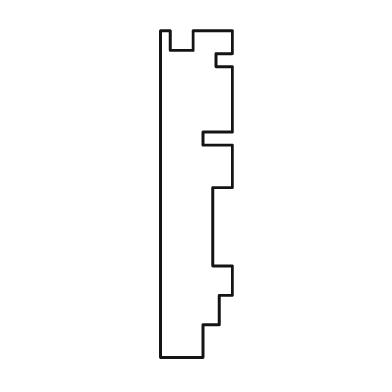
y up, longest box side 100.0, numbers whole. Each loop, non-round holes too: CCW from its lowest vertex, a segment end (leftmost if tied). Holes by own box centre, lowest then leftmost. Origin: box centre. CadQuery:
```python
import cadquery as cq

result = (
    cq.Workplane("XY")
    .moveTo(-11.0, -50.0)
    .lineTo(2.0, -50.0)
    .lineTo(2.0, -40.0)
    .lineTo(7.0, -40.0)
    .lineTo(7.0, -31.0)
    .lineTo(11.0, -31.0)
    .lineTo(11.0, -22.0)
    .lineTo(5.0, -22.0)
    .lineTo(5.0, 2.0)
    .lineTo(11.0, 2.0)
    .lineTo(11.0, 15.0)
    .lineTo(2.0, 15.0)
    .lineTo(2.0, 19.0)
    .lineTo(11.0, 19.0)
    .lineTo(11.0, 39.0)
    .lineTo(6.0, 39.0)
    .lineTo(6.0, 43.0)
    .lineTo(11.0, 43.0)
    .lineTo(11.0, 50.0)
    .lineTo(-1.0, 50.0)
    .lineTo(-1.0, 44.0)
    .lineTo(-8.0, 44.0)
    .lineTo(-8.0, 50.0)
    .lineTo(-11.0, 50.0)
    .close()
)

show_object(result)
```